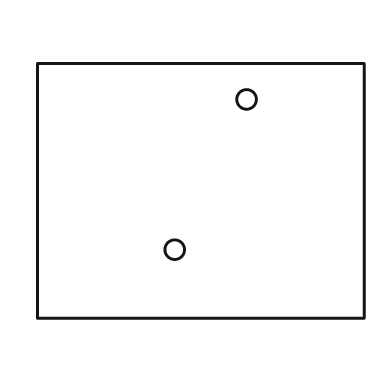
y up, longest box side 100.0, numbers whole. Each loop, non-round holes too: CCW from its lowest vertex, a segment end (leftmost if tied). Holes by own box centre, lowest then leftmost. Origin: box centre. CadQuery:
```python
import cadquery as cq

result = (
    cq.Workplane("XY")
    .moveTo(-50.0, -39.0)
    .lineTo(50.0, -39.0)
    .lineTo(50.0, 39.0)
    .lineTo(-50.0, 39.0)
    .close()
    .moveTo(-8.0, -18.0)
    .circle(3.0)
    .moveTo(14.0, 28.0)
    .circle(3.0)
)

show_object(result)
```